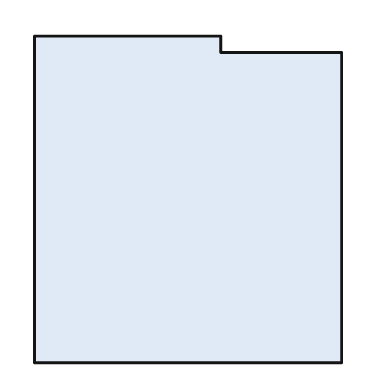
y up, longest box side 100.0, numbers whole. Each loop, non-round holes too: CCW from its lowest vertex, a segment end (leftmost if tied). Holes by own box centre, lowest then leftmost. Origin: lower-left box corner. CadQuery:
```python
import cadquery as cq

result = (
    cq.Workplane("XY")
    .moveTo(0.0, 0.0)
    .lineTo(94.0, 0.0)
    .lineTo(94.0, 95.0)
    .lineTo(57.0, 95.0)
    .lineTo(57.0, 100.0)
    .lineTo(0.0, 100.0)
    .close()
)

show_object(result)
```